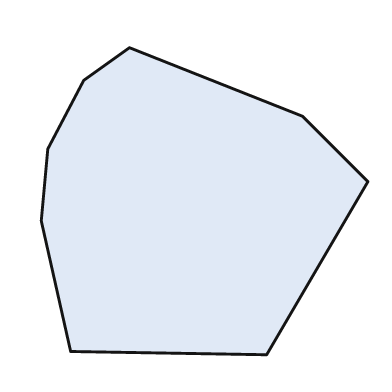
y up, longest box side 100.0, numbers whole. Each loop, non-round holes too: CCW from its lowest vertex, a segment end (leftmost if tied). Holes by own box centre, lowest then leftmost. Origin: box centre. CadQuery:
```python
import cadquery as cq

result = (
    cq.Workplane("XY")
    .moveTo(19.0, -47.0)
    .lineTo(50.0, 6.0)
    .lineTo(30.0, 26.0)
    .lineTo(-23.0, 47.0)
    .lineTo(-37.0, 37.0)
    .lineTo(-48.0, 16.0)
    .lineTo(-50.0, -6.0)
    .lineTo(-41.0, -46.0)
    .close()
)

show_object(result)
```